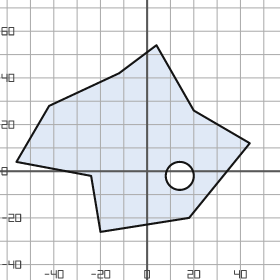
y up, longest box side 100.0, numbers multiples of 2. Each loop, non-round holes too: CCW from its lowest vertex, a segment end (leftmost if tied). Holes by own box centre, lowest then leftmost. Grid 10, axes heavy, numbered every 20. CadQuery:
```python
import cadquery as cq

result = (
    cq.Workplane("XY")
    .moveTo(-20.0, -26.0)
    .lineTo(18.0, -20.0)
    .lineTo(44.0, 12.0)
    .lineTo(20.0, 26.0)
    .lineTo(4.0, 54.0)
    .lineTo(-12.0, 42.0)
    .lineTo(-42.0, 28.0)
    .lineTo(-56.0, 4.0)
    .lineTo(-24.0, -2.0)
    .close()
    .moveTo(14.0, -2.0)
    .circle(6.0)
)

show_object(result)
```